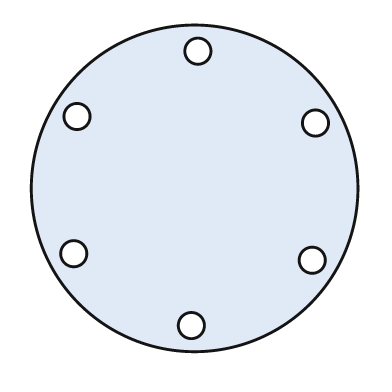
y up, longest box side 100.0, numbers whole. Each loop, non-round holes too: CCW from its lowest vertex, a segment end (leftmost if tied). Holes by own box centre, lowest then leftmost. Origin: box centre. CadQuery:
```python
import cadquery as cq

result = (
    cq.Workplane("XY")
    .moveTo(0.0, 0.0)
    .circle(50.0)
    .moveTo(-1.0, -42.0)
    .circle(4.0)
    .moveTo(36.0, -22.0)
    .circle(4.0)
    .moveTo(-37.0, -20.0)
    .circle(4.0)
    .moveTo(37.0, 20.0)
    .circle(4.0)
    .moveTo(-36.0, 22.0)
    .circle(4.0)
    .moveTo(1.0, 42.0)
    .circle(4.0)
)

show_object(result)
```